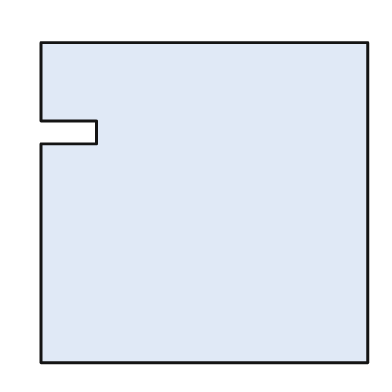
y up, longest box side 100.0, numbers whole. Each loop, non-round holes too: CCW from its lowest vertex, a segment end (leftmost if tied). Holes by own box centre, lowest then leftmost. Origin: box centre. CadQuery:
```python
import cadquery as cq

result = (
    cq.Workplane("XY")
    .moveTo(-50.0, -49.0)
    .lineTo(50.0, -49.0)
    .lineTo(50.0, 49.0)
    .lineTo(-50.0, 49.0)
    .lineTo(-50.0, 25.0)
    .lineTo(-33.0, 25.0)
    .lineTo(-33.0, 18.0)
    .lineTo(-50.0, 18.0)
    .close()
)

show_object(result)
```